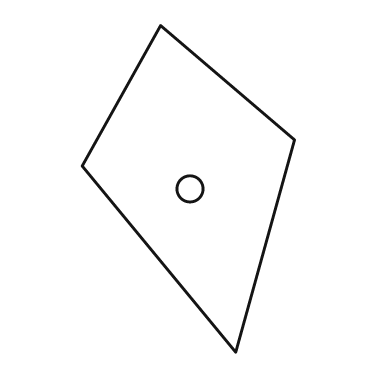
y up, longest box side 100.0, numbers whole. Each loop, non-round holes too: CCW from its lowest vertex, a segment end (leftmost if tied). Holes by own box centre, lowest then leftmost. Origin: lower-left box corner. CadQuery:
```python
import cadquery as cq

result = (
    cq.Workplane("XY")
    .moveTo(47.0, 0.0)
    .lineTo(65.0, 65.0)
    .lineTo(24.0, 100.0)
    .lineTo(0.0, 57.0)
    .close()
    .moveTo(33.0, 50.0)
    .circle(4.0)
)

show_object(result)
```